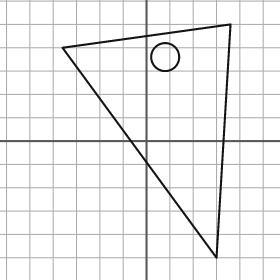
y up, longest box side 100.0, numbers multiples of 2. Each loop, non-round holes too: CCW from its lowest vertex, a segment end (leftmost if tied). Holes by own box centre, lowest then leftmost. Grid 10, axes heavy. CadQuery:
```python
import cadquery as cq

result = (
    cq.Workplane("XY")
    .moveTo(30.0, -50.0)
    .lineTo(36.0, 50.0)
    .lineTo(-36.0, 40.0)
    .close()
    .moveTo(8.0, 36.0)
    .circle(6.0)
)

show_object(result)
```